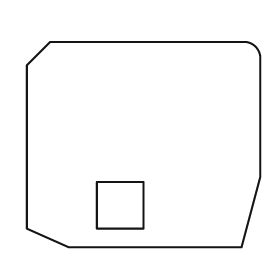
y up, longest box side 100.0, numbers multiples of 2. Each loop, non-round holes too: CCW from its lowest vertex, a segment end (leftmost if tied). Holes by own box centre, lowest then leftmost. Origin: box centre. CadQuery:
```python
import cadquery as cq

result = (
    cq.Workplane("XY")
    .moveTo(-32.0, -44.0)
    .lineTo(42.0, -44.0)
    .lineTo(50.0, -14.0)
    .lineTo(50.0, 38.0)
    .threePointArc((48.0, 42.0), (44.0, 44.0))
    .lineTo(-40.0, 44.0)
    .lineTo(-50.0, 34.0)
    .lineTo(-50.0, -36.0)
    .close()
    .moveTo(-20.0, -36.0)
    .lineTo(0.0, -36.0)
    .lineTo(0.0, -16.0)
    .lineTo(-20.0, -16.0)
    .close()
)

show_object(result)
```